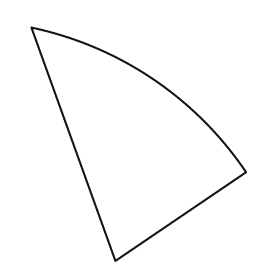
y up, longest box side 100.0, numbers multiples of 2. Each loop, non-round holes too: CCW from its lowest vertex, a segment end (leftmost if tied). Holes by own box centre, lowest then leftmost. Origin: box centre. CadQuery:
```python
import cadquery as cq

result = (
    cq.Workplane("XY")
    .moveTo(-10.0, -50.0)
    .lineTo(46.0, -12.0)
    .threePointArc((6.0, 28.0), (-46.0, 50.0))
    .close()
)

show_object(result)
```